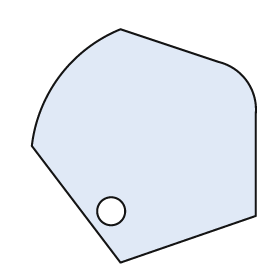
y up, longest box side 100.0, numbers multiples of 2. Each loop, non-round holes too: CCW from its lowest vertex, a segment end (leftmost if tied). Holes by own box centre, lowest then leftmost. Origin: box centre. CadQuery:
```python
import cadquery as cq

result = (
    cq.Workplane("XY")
    .moveTo(-10.0, -50.0)
    .lineTo(48.0, -30.0)
    .lineTo(48.0, 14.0)
    .threePointArc((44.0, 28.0), (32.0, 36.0))
    .lineTo(-10.0, 50.0)
    .threePointArc((-36.0, 30.0), (-48.0, 0.0))
    .close()
    .moveTo(-14.0, -28.0)
    .circle(6.0)
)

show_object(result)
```